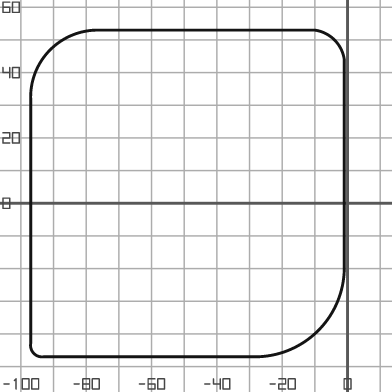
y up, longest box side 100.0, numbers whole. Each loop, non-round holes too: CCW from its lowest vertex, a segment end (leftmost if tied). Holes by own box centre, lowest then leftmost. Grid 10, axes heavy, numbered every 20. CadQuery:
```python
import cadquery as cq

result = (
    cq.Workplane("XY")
    .moveTo(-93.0, -47.0)
    .lineTo(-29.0, -47.0)
    .threePointArc((-9.0, -39.0), (-1.0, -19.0))
    .lineTo(-1.0, 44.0)
    .threePointArc((-4.0, 50.0), (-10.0, 53.0))
    .lineTo(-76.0, 53.0)
    .threePointArc((-91.0, 47.0), (-97.0, 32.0))
    .lineTo(-97.0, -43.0)
    .threePointArc((-96.0, -46.0), (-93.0, -47.0))
    .close()
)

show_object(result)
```